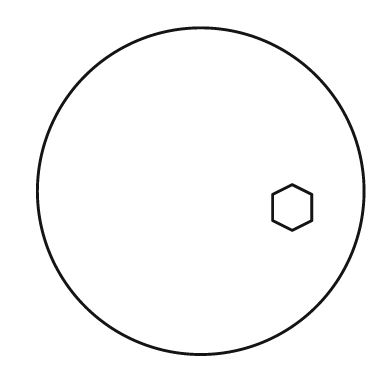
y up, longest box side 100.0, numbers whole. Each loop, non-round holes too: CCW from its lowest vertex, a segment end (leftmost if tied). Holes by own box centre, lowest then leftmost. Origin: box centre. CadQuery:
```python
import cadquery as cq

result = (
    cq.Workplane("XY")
    .moveTo(0.0, 0.0)
    .circle(50.0)
    .moveTo(28.0, -12.0)
    .lineTo(34.0, -9.0)
    .lineTo(34.0, -1.0)
    .lineTo(28.0, 2.0)
    .lineTo(22.0, -1.0)
    .lineTo(22.0, -9.0)
    .close()
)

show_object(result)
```